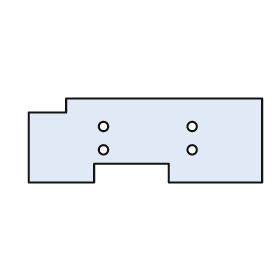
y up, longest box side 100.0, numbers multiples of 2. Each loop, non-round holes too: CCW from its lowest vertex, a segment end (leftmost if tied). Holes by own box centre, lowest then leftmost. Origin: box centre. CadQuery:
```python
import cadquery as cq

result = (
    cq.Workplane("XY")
    .moveTo(-50.0, -18.0)
    .lineTo(-22.0, -18.0)
    .lineTo(-22.0, -10.0)
    .lineTo(10.0, -10.0)
    .lineTo(10.0, -18.0)
    .lineTo(50.0, -18.0)
    .lineTo(50.0, 18.0)
    .lineTo(-34.0, 18.0)
    .lineTo(-34.0, 12.0)
    .lineTo(-50.0, 12.0)
    .close()
    .moveTo(-18.0, -4.0)
    .circle(2.0)
    .moveTo(20.0, -4.0)
    .circle(2.0)
    .moveTo(-18.0, 6.0)
    .circle(2.0)
    .moveTo(20.0, 6.0)
    .circle(2.0)
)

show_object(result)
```